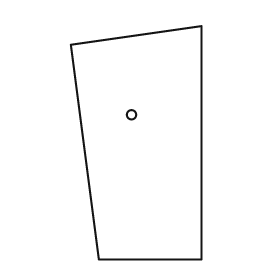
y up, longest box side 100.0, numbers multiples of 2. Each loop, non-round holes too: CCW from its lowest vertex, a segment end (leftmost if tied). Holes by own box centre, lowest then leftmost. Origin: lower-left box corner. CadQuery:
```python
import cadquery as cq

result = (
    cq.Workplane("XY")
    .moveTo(12.0, 0.0)
    .lineTo(56.0, 0.0)
    .lineTo(56.0, 100.0)
    .lineTo(0.0, 92.0)
    .close()
    .moveTo(26.0, 62.0)
    .circle(2.0)
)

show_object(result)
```